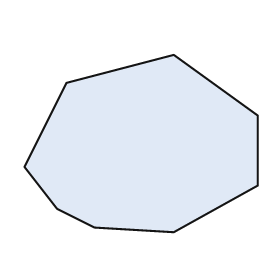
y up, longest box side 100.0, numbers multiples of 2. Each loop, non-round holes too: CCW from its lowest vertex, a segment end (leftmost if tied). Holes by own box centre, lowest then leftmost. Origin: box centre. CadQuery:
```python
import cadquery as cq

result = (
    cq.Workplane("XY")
    .moveTo(14.0, -38.0)
    .lineTo(50.0, -18.0)
    .lineTo(50.0, 12.0)
    .lineTo(14.0, 38.0)
    .lineTo(-32.0, 26.0)
    .lineTo(-50.0, -10.0)
    .lineTo(-36.0, -28.0)
    .lineTo(-20.0, -36.0)
    .close()
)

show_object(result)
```